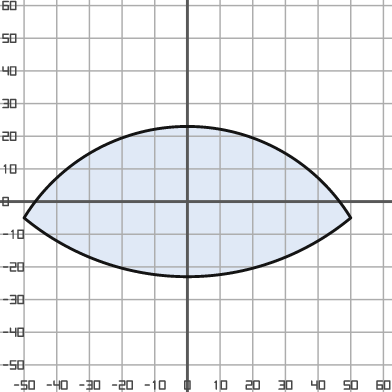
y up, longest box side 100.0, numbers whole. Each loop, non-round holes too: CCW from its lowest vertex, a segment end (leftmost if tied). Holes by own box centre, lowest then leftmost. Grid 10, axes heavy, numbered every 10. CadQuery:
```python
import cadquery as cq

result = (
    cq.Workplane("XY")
    .moveTo(-50.0, -5.0)
    .threePointArc((0.0, -23.0), (50.0, -5.0))
    .threePointArc((0.0, 23.0), (-50.0, -5.0))
    .close()
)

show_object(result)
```